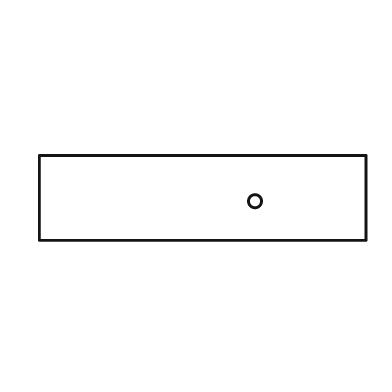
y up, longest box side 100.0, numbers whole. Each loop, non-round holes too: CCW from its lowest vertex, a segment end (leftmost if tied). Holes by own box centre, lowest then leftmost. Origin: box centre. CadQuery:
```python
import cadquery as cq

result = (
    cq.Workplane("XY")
    .moveTo(-50.0, -13.0)
    .lineTo(50.0, -13.0)
    .lineTo(50.0, 13.0)
    .lineTo(-50.0, 13.0)
    .close()
    .moveTo(16.0, -1.0)
    .circle(2.0)
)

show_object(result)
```